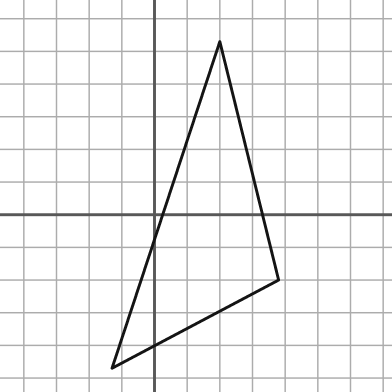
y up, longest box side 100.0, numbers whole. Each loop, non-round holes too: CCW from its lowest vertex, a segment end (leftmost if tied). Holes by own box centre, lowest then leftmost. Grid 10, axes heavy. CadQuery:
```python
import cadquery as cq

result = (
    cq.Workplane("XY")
    .moveTo(-13.0, -47.0)
    .lineTo(38.0, -20.0)
    .lineTo(20.0, 53.0)
    .close()
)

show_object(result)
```